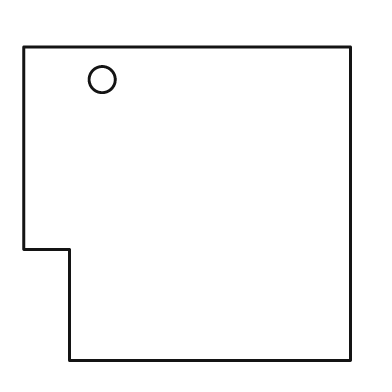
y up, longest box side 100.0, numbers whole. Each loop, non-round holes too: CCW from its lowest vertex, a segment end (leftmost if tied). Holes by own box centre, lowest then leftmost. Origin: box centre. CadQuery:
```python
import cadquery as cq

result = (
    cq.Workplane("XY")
    .moveTo(-36.0, -48.0)
    .lineTo(50.0, -48.0)
    .lineTo(50.0, 48.0)
    .lineTo(-50.0, 48.0)
    .lineTo(-50.0, -14.0)
    .lineTo(-36.0, -14.0)
    .close()
    .moveTo(-26.0, 38.0)
    .circle(4.0)
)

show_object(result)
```